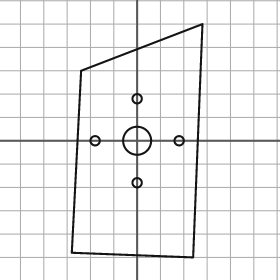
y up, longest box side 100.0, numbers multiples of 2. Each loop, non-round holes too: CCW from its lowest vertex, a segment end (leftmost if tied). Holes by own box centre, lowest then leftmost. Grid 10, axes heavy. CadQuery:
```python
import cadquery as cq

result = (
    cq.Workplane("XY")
    .moveTo(24.0, -50.0)
    .lineTo(28.0, 50.0)
    .lineTo(-24.0, 30.0)
    .lineTo(-28.0, -48.0)
    .close()
    .moveTo(0.0, -18.0)
    .circle(2.0)
    .moveTo(-18.0, 0.0)
    .circle(2.0)
    .moveTo(0.0, 0.0)
    .circle(6.0)
    .moveTo(18.0, 0.0)
    .circle(2.0)
    .moveTo(0.0, 18.0)
    .circle(2.0)
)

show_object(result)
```